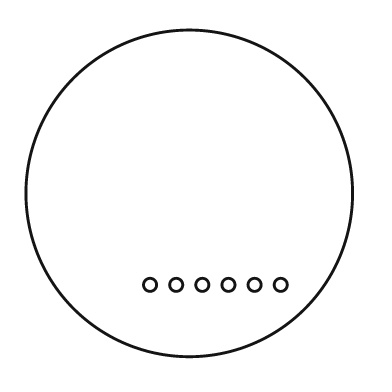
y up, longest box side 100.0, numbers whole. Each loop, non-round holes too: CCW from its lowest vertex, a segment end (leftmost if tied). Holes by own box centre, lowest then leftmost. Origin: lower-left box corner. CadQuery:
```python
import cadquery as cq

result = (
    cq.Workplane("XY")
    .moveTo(50.0, 50.0)
    .circle(50.0)
    .moveTo(38.0, 22.0)
    .circle(2.0)
    .moveTo(46.0, 22.0)
    .circle(2.0)
    .moveTo(54.0, 22.0)
    .circle(2.0)
    .moveTo(62.0, 22.0)
    .circle(2.0)
    .moveTo(70.0, 22.0)
    .circle(2.0)
    .moveTo(78.0, 22.0)
    .circle(2.0)
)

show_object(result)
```